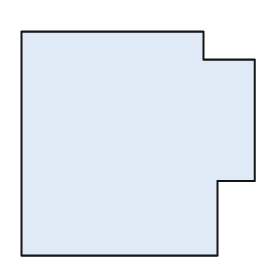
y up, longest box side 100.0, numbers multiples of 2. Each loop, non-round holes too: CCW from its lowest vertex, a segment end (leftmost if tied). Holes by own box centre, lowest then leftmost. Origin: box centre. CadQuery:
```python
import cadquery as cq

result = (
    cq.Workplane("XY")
    .moveTo(-50.0, -48.0)
    .lineTo(34.0, -48.0)
    .lineTo(34.0, -16.0)
    .lineTo(50.0, -16.0)
    .lineTo(50.0, 36.0)
    .lineTo(28.0, 36.0)
    .lineTo(28.0, 48.0)
    .lineTo(-50.0, 48.0)
    .close()
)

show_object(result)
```